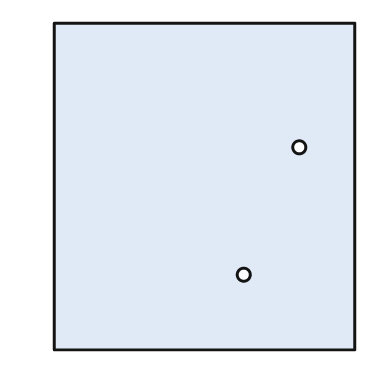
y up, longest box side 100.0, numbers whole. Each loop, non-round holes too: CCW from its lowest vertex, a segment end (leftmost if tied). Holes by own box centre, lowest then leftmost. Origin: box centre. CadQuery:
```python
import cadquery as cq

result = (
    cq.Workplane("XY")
    .moveTo(-46.0, -50.0)
    .lineTo(46.0, -50.0)
    .lineTo(46.0, 50.0)
    .lineTo(-46.0, 50.0)
    .close()
    .moveTo(12.0, -27.0)
    .circle(2.0)
    .moveTo(29.0, 12.0)
    .circle(2.0)
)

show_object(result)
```